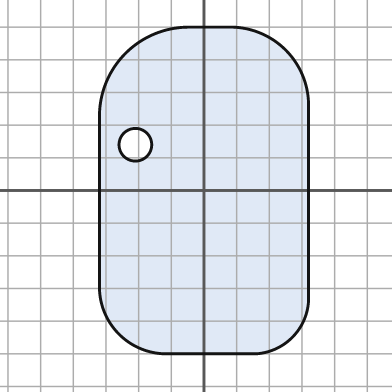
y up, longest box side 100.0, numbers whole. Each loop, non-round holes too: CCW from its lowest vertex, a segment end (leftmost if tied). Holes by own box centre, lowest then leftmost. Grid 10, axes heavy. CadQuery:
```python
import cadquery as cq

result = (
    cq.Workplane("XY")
    .moveTo(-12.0, -50.0)
    .lineTo(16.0, -50.0)
    .threePointArc((27.0, -45.0), (32.0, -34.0))
    .lineTo(32.0, 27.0)
    .threePointArc((25.0, 43.0), (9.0, 50.0))
    .lineTo(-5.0, 50.0)
    .threePointArc((-24.0, 42.0), (-32.0, 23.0))
    .lineTo(-32.0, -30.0)
    .threePointArc((-26.0, -44.0), (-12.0, -50.0))
    .close()
    .moveTo(-21.0, 14.0)
    .circle(5.0)
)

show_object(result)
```